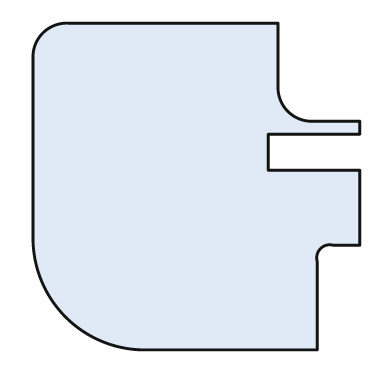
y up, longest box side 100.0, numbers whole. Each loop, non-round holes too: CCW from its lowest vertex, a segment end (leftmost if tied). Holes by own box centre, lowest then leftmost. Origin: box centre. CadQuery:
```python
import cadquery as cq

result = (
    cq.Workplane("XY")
    .moveTo(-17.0, -50.0)
    .lineTo(37.0, -50.0)
    .lineTo(37.0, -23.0)
    .threePointArc((38.0, -19.0), (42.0, -18.0))
    .lineTo(50.0, -18.0)
    .lineTo(50.0, 5.0)
    .lineTo(22.0, 5.0)
    .lineTo(22.0, 16.0)
    .lineTo(50.0, 16.0)
    .lineTo(50.0, 20.0)
    .lineTo(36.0, 20.0)
    .threePointArc((28.0, 23.0), (25.0, 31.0))
    .lineTo(25.0, 50.0)
    .lineTo(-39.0, 50.0)
    .threePointArc((-47.0, 47.0), (-50.0, 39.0))
    .lineTo(-50.0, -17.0)
    .threePointArc((-40.0, -40.0), (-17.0, -50.0))
    .close()
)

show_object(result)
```